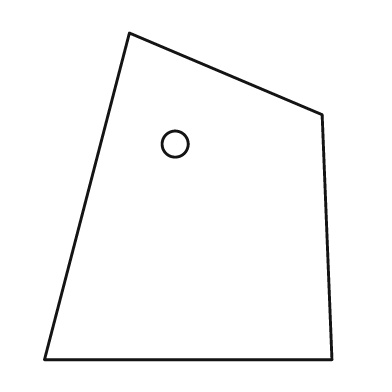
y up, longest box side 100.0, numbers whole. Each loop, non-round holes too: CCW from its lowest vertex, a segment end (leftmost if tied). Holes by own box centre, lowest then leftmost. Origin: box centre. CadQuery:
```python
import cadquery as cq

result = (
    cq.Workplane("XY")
    .moveTo(-44.0, -50.0)
    .lineTo(44.0, -50.0)
    .lineTo(41.0, 25.0)
    .lineTo(-18.0, 50.0)
    .close()
    .moveTo(-4.0, 16.0)
    .circle(4.0)
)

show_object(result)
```